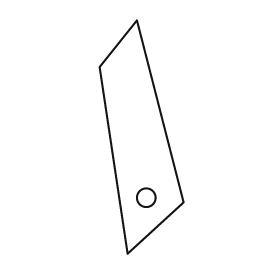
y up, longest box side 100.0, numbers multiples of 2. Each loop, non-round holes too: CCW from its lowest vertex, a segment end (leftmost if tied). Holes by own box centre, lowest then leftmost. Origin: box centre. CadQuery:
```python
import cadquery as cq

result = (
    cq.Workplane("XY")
    .moveTo(-6.0, -50.0)
    .lineTo(18.0, -28.0)
    .lineTo(-2.0, 50.0)
    .lineTo(-18.0, 30.0)
    .close()
    .moveTo(2.0, -26.0)
    .circle(4.0)
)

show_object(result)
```